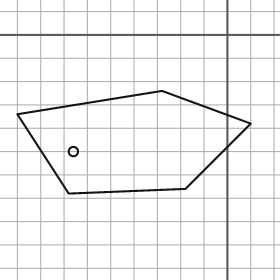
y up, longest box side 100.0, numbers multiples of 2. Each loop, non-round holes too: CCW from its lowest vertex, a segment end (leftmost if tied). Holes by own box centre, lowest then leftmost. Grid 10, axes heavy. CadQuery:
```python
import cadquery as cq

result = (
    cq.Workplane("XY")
    .moveTo(-68.0, -68.0)
    .lineTo(-18.0, -66.0)
    .lineTo(10.0, -38.0)
    .lineTo(-28.0, -24.0)
    .lineTo(-90.0, -34.0)
    .close()
    .moveTo(-66.0, -50.0)
    .circle(2.0)
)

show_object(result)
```